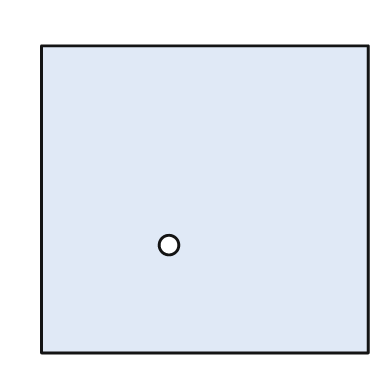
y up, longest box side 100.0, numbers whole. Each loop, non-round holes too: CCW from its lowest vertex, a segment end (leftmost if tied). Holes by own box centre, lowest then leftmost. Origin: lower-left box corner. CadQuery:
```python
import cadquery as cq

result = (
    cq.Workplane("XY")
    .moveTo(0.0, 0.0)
    .lineTo(100.0, 0.0)
    .lineTo(100.0, 94.0)
    .lineTo(0.0, 94.0)
    .close()
    .moveTo(39.0, 33.0)
    .circle(3.0)
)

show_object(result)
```